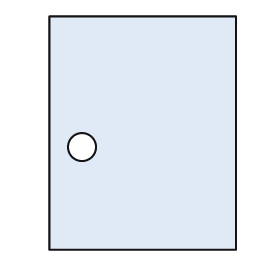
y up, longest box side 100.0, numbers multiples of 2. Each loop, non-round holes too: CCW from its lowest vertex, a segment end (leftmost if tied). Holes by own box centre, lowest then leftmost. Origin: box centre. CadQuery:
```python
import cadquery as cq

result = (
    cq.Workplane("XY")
    .moveTo(-40.0, -50.0)
    .lineTo(40.0, -50.0)
    .lineTo(40.0, 50.0)
    .lineTo(-40.0, 50.0)
    .close()
    .moveTo(-26.0, -6.0)
    .circle(6.0)
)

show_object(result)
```